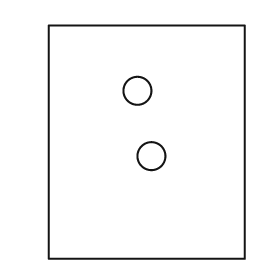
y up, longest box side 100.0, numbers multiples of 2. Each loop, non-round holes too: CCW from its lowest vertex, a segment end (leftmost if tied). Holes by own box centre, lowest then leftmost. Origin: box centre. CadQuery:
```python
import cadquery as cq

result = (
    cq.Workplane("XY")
    .moveTo(-42.0, -50.0)
    .lineTo(42.0, -50.0)
    .lineTo(42.0, 50.0)
    .lineTo(-42.0, 50.0)
    .close()
    .moveTo(2.0, -6.0)
    .circle(6.0)
    .moveTo(-4.0, 22.0)
    .circle(6.0)
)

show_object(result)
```